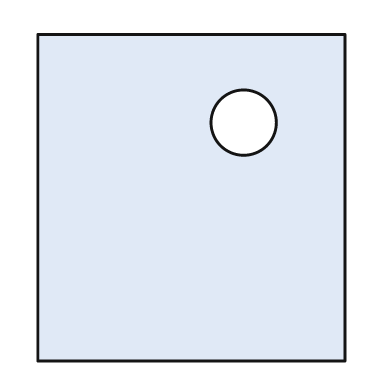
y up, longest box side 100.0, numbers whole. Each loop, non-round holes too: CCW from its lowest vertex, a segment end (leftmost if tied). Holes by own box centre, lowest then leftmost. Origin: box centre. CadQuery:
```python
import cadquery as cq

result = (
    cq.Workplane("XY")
    .moveTo(-47.0, -50.0)
    .lineTo(47.0, -50.0)
    .lineTo(47.0, 50.0)
    .lineTo(-47.0, 50.0)
    .close()
    .moveTo(16.0, 23.0)
    .circle(10.0)
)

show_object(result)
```